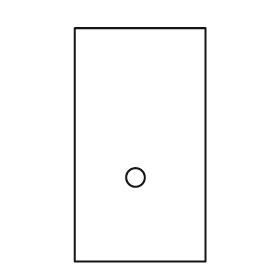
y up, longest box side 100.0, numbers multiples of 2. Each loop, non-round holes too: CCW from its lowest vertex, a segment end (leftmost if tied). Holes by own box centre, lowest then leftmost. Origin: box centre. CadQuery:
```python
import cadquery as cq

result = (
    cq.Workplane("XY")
    .moveTo(-28.0, -50.0)
    .lineTo(28.0, -50.0)
    .lineTo(28.0, 50.0)
    .lineTo(-28.0, 50.0)
    .close()
    .moveTo(-2.0, -14.0)
    .circle(4.0)
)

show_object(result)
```